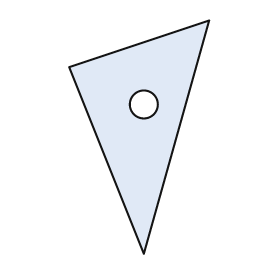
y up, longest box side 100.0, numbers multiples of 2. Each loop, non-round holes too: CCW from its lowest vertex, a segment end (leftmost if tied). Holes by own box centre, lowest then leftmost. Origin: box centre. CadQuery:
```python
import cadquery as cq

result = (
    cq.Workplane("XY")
    .moveTo(2.0, -50.0)
    .lineTo(30.0, 50.0)
    .lineTo(-30.0, 30.0)
    .close()
    .moveTo(2.0, 14.0)
    .circle(6.0)
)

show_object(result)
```